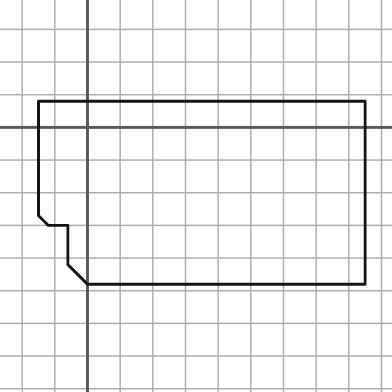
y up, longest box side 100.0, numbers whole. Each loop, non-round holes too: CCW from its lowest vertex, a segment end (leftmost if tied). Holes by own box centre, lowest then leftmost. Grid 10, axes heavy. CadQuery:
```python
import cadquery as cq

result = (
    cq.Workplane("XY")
    .moveTo(0.0, -48.0)
    .lineTo(85.0, -48.0)
    .lineTo(85.0, 8.0)
    .lineTo(-15.0, 8.0)
    .lineTo(-15.0, -27.0)
    .lineTo(-12.0, -30.0)
    .lineTo(-6.0, -30.0)
    .lineTo(-6.0, -42.0)
    .close()
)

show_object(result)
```